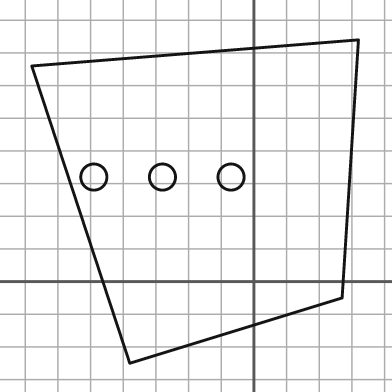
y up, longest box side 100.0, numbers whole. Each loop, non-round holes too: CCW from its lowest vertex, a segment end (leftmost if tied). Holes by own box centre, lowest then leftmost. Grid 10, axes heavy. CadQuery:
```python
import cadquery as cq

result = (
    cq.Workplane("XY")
    .moveTo(-38.0, -25.0)
    .lineTo(27.0, -5.0)
    .lineTo(32.0, 74.0)
    .lineTo(-68.0, 66.0)
    .close()
    .moveTo(-49.0, 32.0)
    .circle(4.0)
    .moveTo(-28.0, 32.0)
    .circle(4.0)
    .moveTo(-7.0, 32.0)
    .circle(4.0)
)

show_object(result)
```